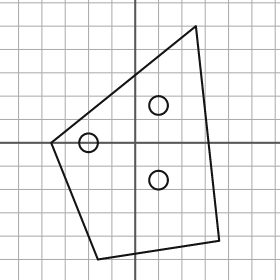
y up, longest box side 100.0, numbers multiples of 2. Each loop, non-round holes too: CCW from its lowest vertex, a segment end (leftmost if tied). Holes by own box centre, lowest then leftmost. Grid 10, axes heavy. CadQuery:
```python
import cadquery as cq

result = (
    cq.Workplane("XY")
    .moveTo(-16.0, -50.0)
    .lineTo(36.0, -42.0)
    .lineTo(26.0, 50.0)
    .lineTo(-36.0, 0.0)
    .close()
    .moveTo(10.0, -16.0)
    .circle(4.0)
    .moveTo(-20.0, 0.0)
    .circle(4.0)
    .moveTo(10.0, 16.0)
    .circle(4.0)
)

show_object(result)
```